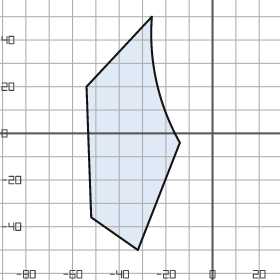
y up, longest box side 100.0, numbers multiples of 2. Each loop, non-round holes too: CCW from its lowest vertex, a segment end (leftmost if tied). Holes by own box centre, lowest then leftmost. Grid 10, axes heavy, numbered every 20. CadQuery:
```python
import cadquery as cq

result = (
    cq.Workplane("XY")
    .moveTo(-32.0, -50.0)
    .lineTo(-14.0, -4.0)
    .threePointArc((-24.0, 22.0), (-26.0, 50.0))
    .lineTo(-54.0, 20.0)
    .lineTo(-52.0, -36.0)
    .close()
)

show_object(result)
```